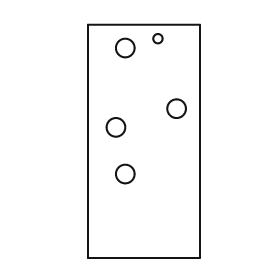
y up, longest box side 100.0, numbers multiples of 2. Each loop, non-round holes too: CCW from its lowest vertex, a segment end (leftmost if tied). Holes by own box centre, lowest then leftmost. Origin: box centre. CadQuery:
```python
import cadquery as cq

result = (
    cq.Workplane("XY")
    .moveTo(-24.0, -50.0)
    .lineTo(24.0, -50.0)
    .lineTo(24.0, 50.0)
    .lineTo(-24.0, 50.0)
    .close()
    .moveTo(-8.0, -14.0)
    .circle(4.0)
    .moveTo(-12.0, 6.0)
    .circle(4.0)
    .moveTo(14.0, 14.0)
    .circle(4.0)
    .moveTo(-8.0, 40.0)
    .circle(4.0)
    .moveTo(6.0, 44.0)
    .circle(2.0)
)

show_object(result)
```